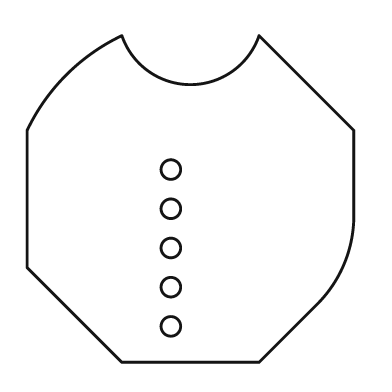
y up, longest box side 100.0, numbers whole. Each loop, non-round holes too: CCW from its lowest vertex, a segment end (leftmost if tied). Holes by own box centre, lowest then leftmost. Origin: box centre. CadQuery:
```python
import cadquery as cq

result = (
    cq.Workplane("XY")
    .moveTo(-21.0, -50.0)
    .lineTo(21.0, -50.0)
    .lineTo(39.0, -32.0)
    .threePointArc((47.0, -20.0), (50.0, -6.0))
    .lineTo(50.0, 21.0)
    .lineTo(21.0, 50.0)
    .threePointArc((0.0, 35.0), (-21.0, 50.0))
    .threePointArc((-38.0, 38.0), (-50.0, 21.0))
    .lineTo(-50.0, -21.0)
    .close()
    .moveTo(-6.0, -39.0)
    .circle(3.0)
    .moveTo(-6.0, -27.0)
    .circle(3.0)
    .moveTo(-6.0, -15.0)
    .circle(3.0)
    .moveTo(-6.0, -3.0)
    .circle(3.0)
    .moveTo(-6.0, 9.0)
    .circle(3.0)
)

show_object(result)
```